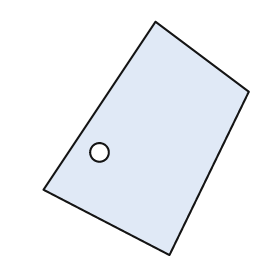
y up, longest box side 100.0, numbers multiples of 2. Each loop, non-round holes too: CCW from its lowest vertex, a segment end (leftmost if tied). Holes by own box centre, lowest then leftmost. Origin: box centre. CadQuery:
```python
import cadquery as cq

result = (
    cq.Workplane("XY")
    .moveTo(10.0, -50.0)
    .lineTo(44.0, 20.0)
    .lineTo(4.0, 50.0)
    .lineTo(-44.0, -22.0)
    .close()
    .moveTo(-20.0, -6.0)
    .circle(4.0)
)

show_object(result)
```